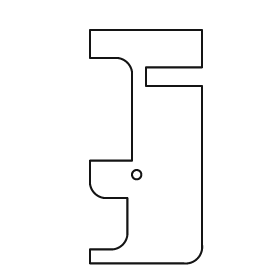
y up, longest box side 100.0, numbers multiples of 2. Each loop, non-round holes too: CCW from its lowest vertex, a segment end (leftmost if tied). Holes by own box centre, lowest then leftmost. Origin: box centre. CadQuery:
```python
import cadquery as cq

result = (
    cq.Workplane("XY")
    .moveTo(-24.0, -50.0)
    .lineTo(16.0, -50.0)
    .threePointArc((22.0, -48.0), (24.0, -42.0))
    .lineTo(24.0, 26.0)
    .lineTo(0.0, 26.0)
    .lineTo(0.0, 34.0)
    .lineTo(24.0, 34.0)
    .lineTo(24.0, 50.0)
    .lineTo(-24.0, 50.0)
    .lineTo(-24.0, 38.0)
    .lineTo(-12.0, 38.0)
    .threePointArc((-8.0, 36.0), (-6.0, 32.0))
    .lineTo(-6.0, -6.0)
    .lineTo(-24.0, -6.0)
    .lineTo(-24.0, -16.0)
    .threePointArc((-22.0, -20.0), (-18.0, -22.0))
    .lineTo(-8.0, -22.0)
    .lineTo(-8.0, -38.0)
    .threePointArc((-10.0, -42.0), (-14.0, -44.0))
    .lineTo(-24.0, -44.0)
    .close()
    .moveTo(-4.0, -12.0)
    .circle(2.0)
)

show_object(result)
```